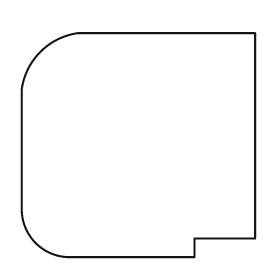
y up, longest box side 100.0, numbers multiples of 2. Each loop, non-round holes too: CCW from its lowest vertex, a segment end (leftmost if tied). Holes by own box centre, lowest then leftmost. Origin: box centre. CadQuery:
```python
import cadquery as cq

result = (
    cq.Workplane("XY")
    .moveTo(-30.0, -48.0)
    .lineTo(24.0, -48.0)
    .lineTo(24.0, -40.0)
    .lineTo(50.0, -40.0)
    .lineTo(50.0, 48.0)
    .lineTo(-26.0, 48.0)
    .threePointArc((-42.0, 40.0), (-50.0, 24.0))
    .lineTo(-50.0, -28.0)
    .threePointArc((-44.0, -42.0), (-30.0, -48.0))
    .close()
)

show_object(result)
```